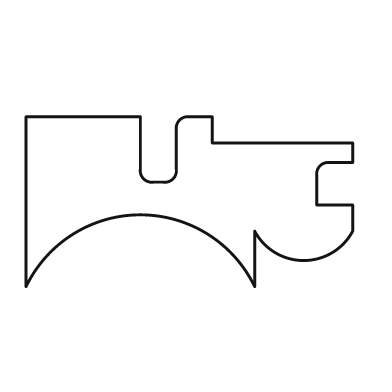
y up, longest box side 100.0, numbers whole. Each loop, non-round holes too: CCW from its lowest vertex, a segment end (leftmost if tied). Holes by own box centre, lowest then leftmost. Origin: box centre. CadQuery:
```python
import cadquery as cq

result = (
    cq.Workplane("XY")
    .moveTo(-50.0, -26.0)
    .threePointArc((-15.0, -4.0), (20.0, -26.0))
    .lineTo(20.0, -9.0)
    .threePointArc((35.0, -18.0), (50.0, -9.0))
    .lineTo(50.0, -1.0)
    .lineTo(39.0, -1.0)
    .lineTo(39.0, 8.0)
    .threePointArc((40.0, 11.0), (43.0, 12.0))
    .lineTo(50.0, 12.0)
    .lineTo(50.0, 18.0)
    .lineTo(7.0, 18.0)
    .lineTo(7.0, 26.0)
    .lineTo(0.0, 26.0)
    .threePointArc((-3.0, 25.0), (-4.0, 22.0))
    .lineTo(-4.0, 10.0)
    .threePointArc((-5.0, 7.0), (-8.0, 6.0))
    .lineTo(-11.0, 6.0)
    .threePointArc((-14.0, 7.0), (-15.0, 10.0))
    .lineTo(-15.0, 26.0)
    .lineTo(-50.0, 26.0)
    .close()
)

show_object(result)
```